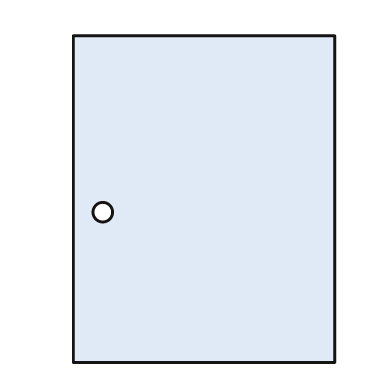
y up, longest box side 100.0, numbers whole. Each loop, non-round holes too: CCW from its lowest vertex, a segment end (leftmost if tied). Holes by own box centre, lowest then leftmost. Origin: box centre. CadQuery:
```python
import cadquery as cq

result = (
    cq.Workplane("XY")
    .moveTo(-40.0, -50.0)
    .lineTo(40.0, -50.0)
    .lineTo(40.0, 50.0)
    .lineTo(-40.0, 50.0)
    .close()
    .moveTo(-31.0, -4.0)
    .circle(3.0)
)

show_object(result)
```